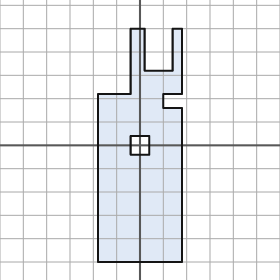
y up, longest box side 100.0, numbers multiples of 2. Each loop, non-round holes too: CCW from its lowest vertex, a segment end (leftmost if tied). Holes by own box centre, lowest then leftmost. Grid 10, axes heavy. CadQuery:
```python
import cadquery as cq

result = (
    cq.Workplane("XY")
    .moveTo(-18.0, -50.0)
    .lineTo(18.0, -50.0)
    .lineTo(18.0, 16.0)
    .lineTo(10.0, 16.0)
    .lineTo(10.0, 22.0)
    .lineTo(18.0, 22.0)
    .lineTo(18.0, 50.0)
    .lineTo(14.0, 50.0)
    .lineTo(14.0, 32.0)
    .lineTo(2.0, 32.0)
    .lineTo(2.0, 50.0)
    .lineTo(-4.0, 50.0)
    .lineTo(-4.0, 22.0)
    .lineTo(-18.0, 22.0)
    .close()
    .moveTo(-4.0, -4.0)
    .lineTo(4.0, -4.0)
    .lineTo(4.0, 4.0)
    .lineTo(-4.0, 4.0)
    .close()
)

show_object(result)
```